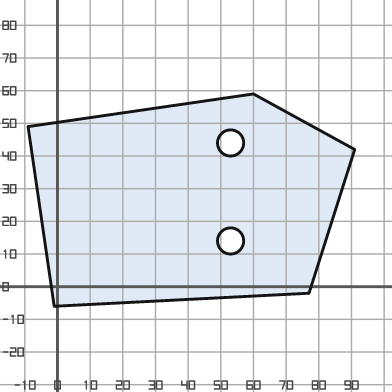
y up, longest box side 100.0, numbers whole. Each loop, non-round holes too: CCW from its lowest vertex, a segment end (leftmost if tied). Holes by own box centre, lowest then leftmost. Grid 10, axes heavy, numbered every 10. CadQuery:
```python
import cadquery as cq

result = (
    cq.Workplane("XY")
    .moveTo(-1.0, -6.0)
    .lineTo(77.0, -2.0)
    .lineTo(91.0, 42.0)
    .lineTo(60.0, 59.0)
    .lineTo(-9.0, 49.0)
    .close()
    .moveTo(53.0, 14.0)
    .circle(4.0)
    .moveTo(53.0, 44.0)
    .circle(4.0)
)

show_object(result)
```